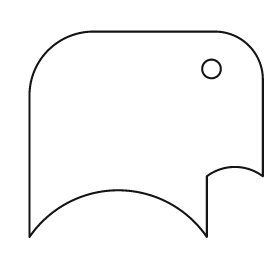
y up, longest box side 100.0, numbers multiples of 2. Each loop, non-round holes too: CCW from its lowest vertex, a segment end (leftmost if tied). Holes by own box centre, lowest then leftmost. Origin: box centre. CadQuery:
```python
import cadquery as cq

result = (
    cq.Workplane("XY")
    .moveTo(-50.0, -44.0)
    .threePointArc((-12.0, -24.0), (26.0, -44.0))
    .lineTo(26.0, -18.0)
    .threePointArc((38.0, -14.0), (50.0, -18.0))
    .lineTo(50.0, 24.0)
    .threePointArc((44.0, 38.0), (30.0, 44.0))
    .lineTo(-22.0, 44.0)
    .threePointArc((-42.0, 36.0), (-50.0, 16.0))
    .close()
    .moveTo(28.0, 28.0)
    .circle(4.0)
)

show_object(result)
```